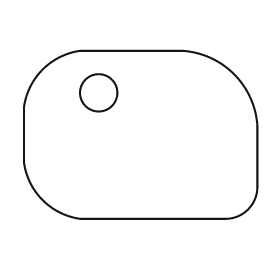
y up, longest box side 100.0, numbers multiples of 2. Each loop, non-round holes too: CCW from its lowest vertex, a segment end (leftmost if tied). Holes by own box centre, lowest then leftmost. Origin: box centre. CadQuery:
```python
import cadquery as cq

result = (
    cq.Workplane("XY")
    .moveTo(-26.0, -36.0)
    .lineTo(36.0, -36.0)
    .threePointArc((46.0, -32.0), (50.0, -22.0))
    .lineTo(50.0, 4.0)
    .threePointArc((40.0, 26.0), (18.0, 36.0))
    .lineTo(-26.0, 36.0)
    .threePointArc((-42.0, 28.0), (-50.0, 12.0))
    .lineTo(-50.0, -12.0)
    .threePointArc((-42.0, -28.0), (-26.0, -36.0))
    .close()
    .moveTo(-18.0, 18.0)
    .circle(8.0)
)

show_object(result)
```